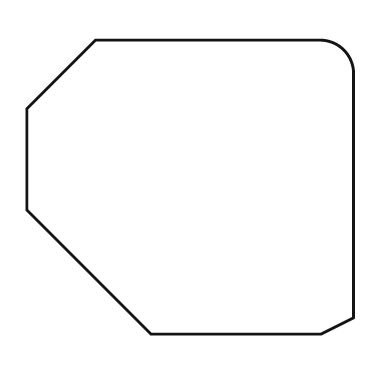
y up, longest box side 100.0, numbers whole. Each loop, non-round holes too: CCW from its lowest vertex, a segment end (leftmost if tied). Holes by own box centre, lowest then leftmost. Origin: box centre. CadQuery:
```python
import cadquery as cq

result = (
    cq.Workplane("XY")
    .moveTo(-12.0, -45.0)
    .lineTo(40.0, -45.0)
    .lineTo(50.0, -40.0)
    .lineTo(50.0, 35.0)
    .threePointArc((47.0, 42.0), (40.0, 45.0))
    .lineTo(-29.0, 45.0)
    .lineTo(-50.0, 24.0)
    .lineTo(-50.0, -7.0)
    .close()
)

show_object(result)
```